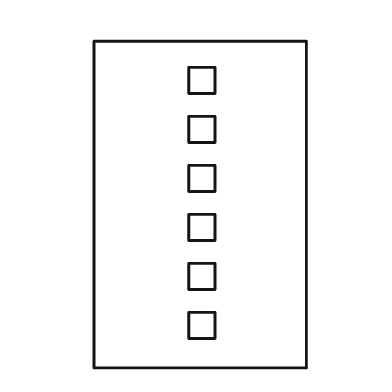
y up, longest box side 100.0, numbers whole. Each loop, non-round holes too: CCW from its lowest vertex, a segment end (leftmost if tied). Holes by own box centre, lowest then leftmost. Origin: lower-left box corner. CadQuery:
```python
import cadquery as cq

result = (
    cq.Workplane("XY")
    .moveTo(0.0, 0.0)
    .lineTo(65.0, 0.0)
    .lineTo(65.0, 100.0)
    .lineTo(0.0, 100.0)
    .close()
    .moveTo(29.0, 9.0)
    .lineTo(37.0, 9.0)
    .lineTo(37.0, 17.0)
    .lineTo(29.0, 17.0)
    .close()
    .moveTo(29.0, 24.0)
    .lineTo(37.0, 24.0)
    .lineTo(37.0, 32.0)
    .lineTo(29.0, 32.0)
    .close()
    .moveTo(29.0, 39.0)
    .lineTo(37.0, 39.0)
    .lineTo(37.0, 47.0)
    .lineTo(29.0, 47.0)
    .close()
    .moveTo(29.0, 54.0)
    .lineTo(37.0, 54.0)
    .lineTo(37.0, 62.0)
    .lineTo(29.0, 62.0)
    .close()
    .moveTo(29.0, 69.0)
    .lineTo(37.0, 69.0)
    .lineTo(37.0, 77.0)
    .lineTo(29.0, 77.0)
    .close()
    .moveTo(29.0, 84.0)
    .lineTo(37.0, 84.0)
    .lineTo(37.0, 92.0)
    .lineTo(29.0, 92.0)
    .close()
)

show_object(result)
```